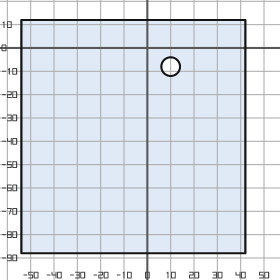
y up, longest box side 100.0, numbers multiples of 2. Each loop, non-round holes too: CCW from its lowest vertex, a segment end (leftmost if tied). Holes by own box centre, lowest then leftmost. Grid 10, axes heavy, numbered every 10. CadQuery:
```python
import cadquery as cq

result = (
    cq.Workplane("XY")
    .moveTo(-54.0, -88.0)
    .lineTo(42.0, -88.0)
    .lineTo(42.0, 12.0)
    .lineTo(-54.0, 12.0)
    .close()
    .moveTo(10.0, -8.0)
    .circle(4.0)
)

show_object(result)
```